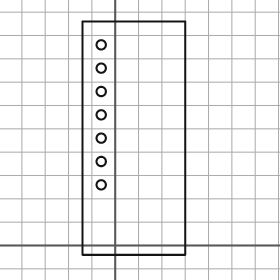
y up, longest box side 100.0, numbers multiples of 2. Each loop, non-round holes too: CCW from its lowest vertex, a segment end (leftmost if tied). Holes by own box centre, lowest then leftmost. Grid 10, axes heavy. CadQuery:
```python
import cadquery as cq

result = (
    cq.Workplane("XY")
    .moveTo(-14.0, -4.0)
    .lineTo(30.0, -4.0)
    .lineTo(30.0, 96.0)
    .lineTo(-14.0, 96.0)
    .close()
    .moveTo(-6.0, 26.0)
    .circle(2.0)
    .moveTo(-6.0, 36.0)
    .circle(2.0)
    .moveTo(-6.0, 46.0)
    .circle(2.0)
    .moveTo(-6.0, 56.0)
    .circle(2.0)
    .moveTo(-6.0, 66.0)
    .circle(2.0)
    .moveTo(-6.0, 76.0)
    .circle(2.0)
    .moveTo(-6.0, 86.0)
    .circle(2.0)
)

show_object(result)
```